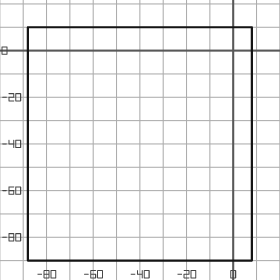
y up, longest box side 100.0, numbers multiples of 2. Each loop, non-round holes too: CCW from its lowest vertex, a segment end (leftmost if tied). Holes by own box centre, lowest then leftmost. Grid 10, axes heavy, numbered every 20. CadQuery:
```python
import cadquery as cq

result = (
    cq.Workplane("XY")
    .moveTo(-88.0, -90.0)
    .lineTo(8.0, -90.0)
    .lineTo(8.0, 10.0)
    .lineTo(-88.0, 10.0)
    .close()
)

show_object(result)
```